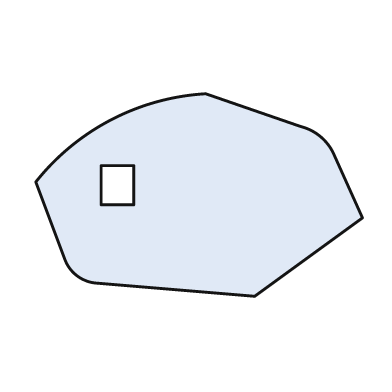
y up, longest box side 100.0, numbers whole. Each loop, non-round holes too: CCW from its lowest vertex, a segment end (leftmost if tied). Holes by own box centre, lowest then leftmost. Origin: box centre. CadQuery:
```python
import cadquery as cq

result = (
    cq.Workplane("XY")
    .moveTo(17.0, -31.0)
    .lineTo(50.0, -7.0)
    .lineTo(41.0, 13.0)
    .threePointArc((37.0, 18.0), (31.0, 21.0))
    .lineTo(2.0, 31.0)
    .threePointArc((-27.0, 23.0), (-50.0, 4.0))
    .lineTo(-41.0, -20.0)
    .threePointArc((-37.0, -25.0), (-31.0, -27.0))
    .close()
    .moveTo(-30.0, -3.0)
    .lineTo(-20.0, -3.0)
    .lineTo(-20.0, 9.0)
    .lineTo(-30.0, 9.0)
    .close()
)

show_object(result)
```